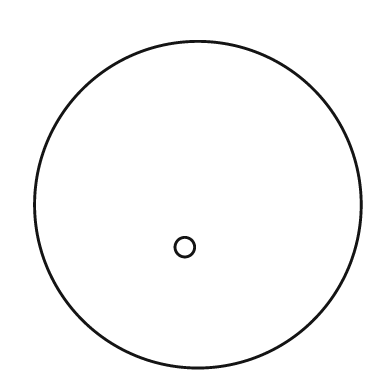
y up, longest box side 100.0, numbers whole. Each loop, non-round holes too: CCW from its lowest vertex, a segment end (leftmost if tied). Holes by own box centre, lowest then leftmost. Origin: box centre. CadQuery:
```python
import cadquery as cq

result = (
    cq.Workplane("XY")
    .moveTo(0.0, 0.0)
    .circle(50.0)
    .moveTo(-4.0, -13.0)
    .circle(3.0)
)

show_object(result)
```